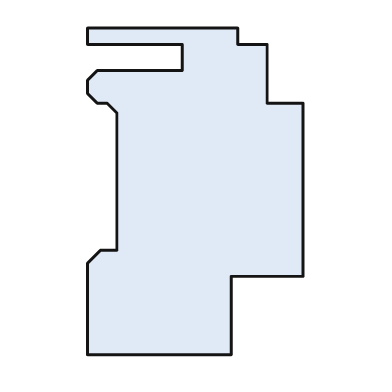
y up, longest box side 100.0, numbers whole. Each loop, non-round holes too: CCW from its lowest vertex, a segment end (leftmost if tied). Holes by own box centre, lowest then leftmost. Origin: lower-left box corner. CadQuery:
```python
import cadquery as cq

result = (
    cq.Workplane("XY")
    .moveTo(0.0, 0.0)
    .lineTo(44.0, 0.0)
    .lineTo(44.0, 24.0)
    .lineTo(66.0, 24.0)
    .lineTo(66.0, 77.0)
    .lineTo(55.0, 77.0)
    .lineTo(55.0, 95.0)
    .lineTo(46.0, 95.0)
    .lineTo(46.0, 100.0)
    .lineTo(0.0, 100.0)
    .lineTo(0.0, 95.0)
    .lineTo(29.0, 95.0)
    .lineTo(29.0, 87.0)
    .lineTo(3.0, 87.0)
    .lineTo(0.0, 84.0)
    .lineTo(0.0, 80.0)
    .lineTo(3.0, 77.0)
    .lineTo(6.0, 77.0)
    .lineTo(9.0, 74.0)
    .lineTo(9.0, 32.0)
    .lineTo(4.0, 32.0)
    .lineTo(0.0, 28.0)
    .close()
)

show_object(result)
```